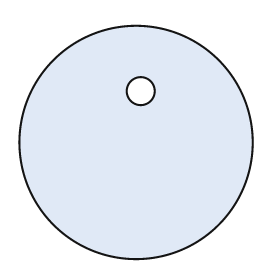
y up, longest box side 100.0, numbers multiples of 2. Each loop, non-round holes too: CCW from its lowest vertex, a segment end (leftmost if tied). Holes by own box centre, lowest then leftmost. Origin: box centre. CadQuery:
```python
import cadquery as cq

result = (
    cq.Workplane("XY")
    .moveTo(0.0, 0.0)
    .circle(50.0)
    .moveTo(2.0, 22.0)
    .circle(6.0)
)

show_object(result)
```